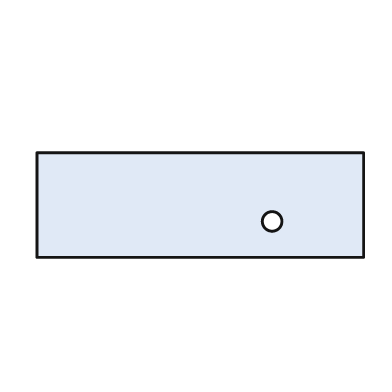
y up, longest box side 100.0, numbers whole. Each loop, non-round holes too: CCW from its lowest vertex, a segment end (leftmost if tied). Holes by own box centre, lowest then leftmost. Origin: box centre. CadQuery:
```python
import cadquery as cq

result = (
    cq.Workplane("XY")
    .moveTo(-50.0, -16.0)
    .lineTo(50.0, -16.0)
    .lineTo(50.0, 16.0)
    .lineTo(-50.0, 16.0)
    .close()
    .moveTo(22.0, -5.0)
    .circle(3.0)
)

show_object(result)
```